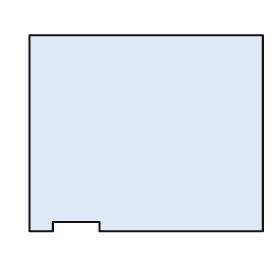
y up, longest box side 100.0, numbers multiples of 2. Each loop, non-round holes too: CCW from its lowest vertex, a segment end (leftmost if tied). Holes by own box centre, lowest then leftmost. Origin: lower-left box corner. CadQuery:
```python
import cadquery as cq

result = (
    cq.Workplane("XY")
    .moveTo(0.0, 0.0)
    .lineTo(10.0, 0.0)
    .lineTo(10.0, 4.0)
    .lineTo(30.0, 4.0)
    .lineTo(30.0, 0.0)
    .lineTo(100.0, 0.0)
    .lineTo(100.0, 84.0)
    .lineTo(0.0, 84.0)
    .close()
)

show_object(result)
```